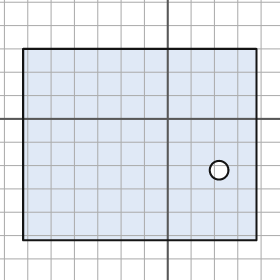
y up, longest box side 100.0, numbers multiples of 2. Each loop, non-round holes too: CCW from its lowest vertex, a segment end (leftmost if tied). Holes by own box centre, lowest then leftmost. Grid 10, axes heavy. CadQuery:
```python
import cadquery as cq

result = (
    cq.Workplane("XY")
    .moveTo(-62.0, -52.0)
    .lineTo(38.0, -52.0)
    .lineTo(38.0, 30.0)
    .lineTo(-62.0, 30.0)
    .close()
    .moveTo(22.0, -22.0)
    .circle(4.0)
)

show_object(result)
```